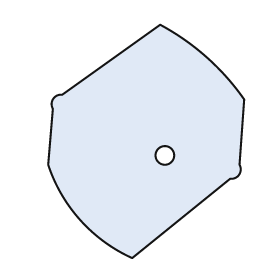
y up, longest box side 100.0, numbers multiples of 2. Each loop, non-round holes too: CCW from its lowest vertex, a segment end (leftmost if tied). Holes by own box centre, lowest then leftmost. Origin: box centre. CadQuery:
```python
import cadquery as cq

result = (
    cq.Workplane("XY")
    .moveTo(-6.0, -50.0)
    .lineTo(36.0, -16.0)
    .threePointArc((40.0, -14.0), (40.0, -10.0))
    .lineTo(42.0, 18.0)
    .threePointArc((26.0, 36.0), (6.0, 50.0))
    .lineTo(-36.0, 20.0)
    .threePointArc((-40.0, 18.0), (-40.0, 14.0))
    .lineTo(-42.0, -10.0)
    .threePointArc((-28.0, -34.0), (-6.0, -50.0))
    .close()
    .moveTo(8.0, -6.0)
    .circle(4.0)
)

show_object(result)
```